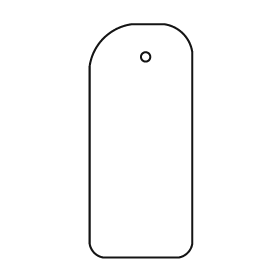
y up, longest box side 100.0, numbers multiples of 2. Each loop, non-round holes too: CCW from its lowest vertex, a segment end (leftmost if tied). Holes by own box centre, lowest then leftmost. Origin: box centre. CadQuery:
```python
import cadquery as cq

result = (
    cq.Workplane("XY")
    .moveTo(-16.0, -50.0)
    .lineTo(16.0, -50.0)
    .threePointArc((20.0, -48.0), (22.0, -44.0))
    .lineTo(22.0, 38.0)
    .threePointArc((18.0, 46.0), (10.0, 50.0))
    .lineTo(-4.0, 50.0)
    .threePointArc((-16.0, 44.0), (-22.0, 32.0))
    .lineTo(-22.0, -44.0)
    .threePointArc((-20.0, -48.0), (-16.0, -50.0))
    .close()
    .moveTo(2.0, 36.0)
    .circle(2.0)
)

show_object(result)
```